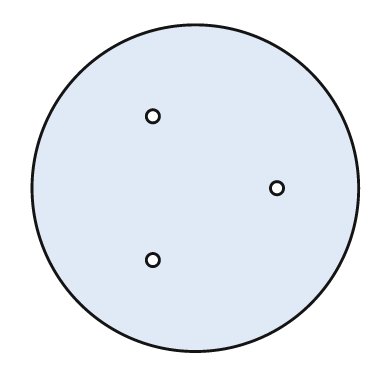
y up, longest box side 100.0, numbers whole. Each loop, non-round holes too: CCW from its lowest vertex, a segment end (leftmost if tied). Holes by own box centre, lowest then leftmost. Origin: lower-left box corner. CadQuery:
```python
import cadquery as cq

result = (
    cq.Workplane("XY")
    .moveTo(50.0, 50.0)
    .circle(50.0)
    .moveTo(37.0, 28.0)
    .circle(2.0)
    .moveTo(75.0, 50.0)
    .circle(2.0)
    .moveTo(37.0, 72.0)
    .circle(2.0)
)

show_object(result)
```